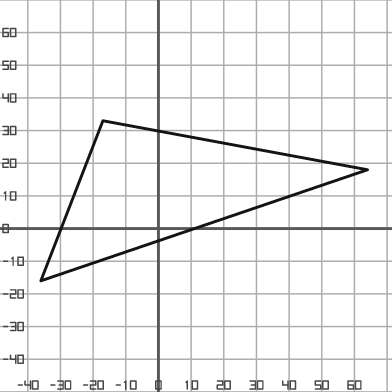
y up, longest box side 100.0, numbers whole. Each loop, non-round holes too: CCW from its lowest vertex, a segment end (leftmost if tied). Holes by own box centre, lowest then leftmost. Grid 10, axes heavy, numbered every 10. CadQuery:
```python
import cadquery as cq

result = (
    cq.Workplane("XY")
    .moveTo(-36.0, -16.0)
    .lineTo(64.0, 18.0)
    .lineTo(-17.0, 33.0)
    .close()
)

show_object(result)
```